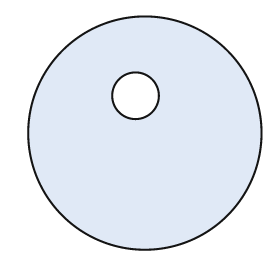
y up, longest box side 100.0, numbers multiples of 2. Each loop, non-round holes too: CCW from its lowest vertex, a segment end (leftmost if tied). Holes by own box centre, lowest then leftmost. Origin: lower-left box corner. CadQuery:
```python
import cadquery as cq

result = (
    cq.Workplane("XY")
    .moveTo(50.0, 50.0)
    .circle(50.0)
    .moveTo(46.0, 66.0)
    .circle(10.0)
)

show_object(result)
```